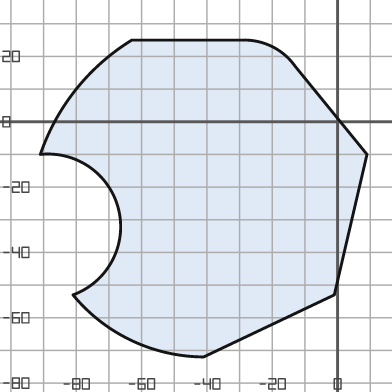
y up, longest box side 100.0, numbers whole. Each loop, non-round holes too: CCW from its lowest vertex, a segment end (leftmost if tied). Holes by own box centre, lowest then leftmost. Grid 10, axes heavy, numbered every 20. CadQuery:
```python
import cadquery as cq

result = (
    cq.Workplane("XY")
    .moveTo(-41.0, -72.0)
    .lineTo(-1.0, -53.0)
    .lineTo(9.0, -10.0)
    .lineTo(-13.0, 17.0)
    .threePointArc((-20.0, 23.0), (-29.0, 25.0))
    .lineTo(-63.0, 25.0)
    .threePointArc((-80.0, 10.0), (-91.0, -10.0))
    .threePointArc((-67.0, -27.0), (-81.0, -53.0))
    .threePointArc((-63.0, -67.0), (-41.0, -72.0))
    .close()
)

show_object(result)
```